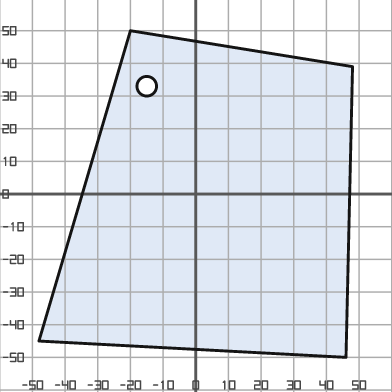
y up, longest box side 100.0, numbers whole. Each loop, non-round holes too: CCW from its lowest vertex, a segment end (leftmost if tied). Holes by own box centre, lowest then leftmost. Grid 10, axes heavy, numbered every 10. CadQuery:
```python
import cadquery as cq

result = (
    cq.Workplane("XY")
    .moveTo(46.0, -50.0)
    .lineTo(48.0, 39.0)
    .lineTo(-20.0, 50.0)
    .lineTo(-48.0, -45.0)
    .close()
    .moveTo(-15.0, 33.0)
    .circle(3.0)
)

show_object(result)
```